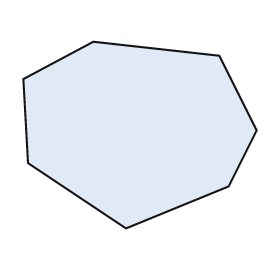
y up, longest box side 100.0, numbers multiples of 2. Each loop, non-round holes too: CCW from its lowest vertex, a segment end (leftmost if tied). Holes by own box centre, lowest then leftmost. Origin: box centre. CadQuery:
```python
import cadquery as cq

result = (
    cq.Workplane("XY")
    .moveTo(-6.0, -40.0)
    .lineTo(38.0, -22.0)
    .lineTo(50.0, 2.0)
    .lineTo(34.0, 34.0)
    .lineTo(-20.0, 40.0)
    .lineTo(-50.0, 24.0)
    .lineTo(-48.0, -12.0)
    .close()
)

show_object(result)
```